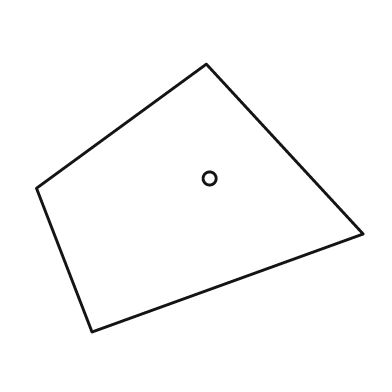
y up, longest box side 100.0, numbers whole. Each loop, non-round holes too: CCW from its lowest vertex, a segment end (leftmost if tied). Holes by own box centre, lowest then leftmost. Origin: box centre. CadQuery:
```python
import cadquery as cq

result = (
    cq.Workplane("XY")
    .moveTo(-33.0, -41.0)
    .lineTo(50.0, -11.0)
    .lineTo(2.0, 41.0)
    .lineTo(-50.0, 3.0)
    .close()
    .moveTo(3.0, 6.0)
    .circle(2.0)
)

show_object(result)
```